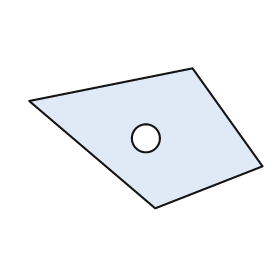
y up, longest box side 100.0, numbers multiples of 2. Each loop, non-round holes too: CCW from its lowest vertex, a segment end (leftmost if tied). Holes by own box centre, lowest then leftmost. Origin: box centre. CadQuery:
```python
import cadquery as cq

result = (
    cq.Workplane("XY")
    .moveTo(4.0, -30.0)
    .lineTo(50.0, -12.0)
    .lineTo(20.0, 30.0)
    .lineTo(-50.0, 16.0)
    .close()
    .moveTo(0.0, 0.0)
    .circle(6.0)
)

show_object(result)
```